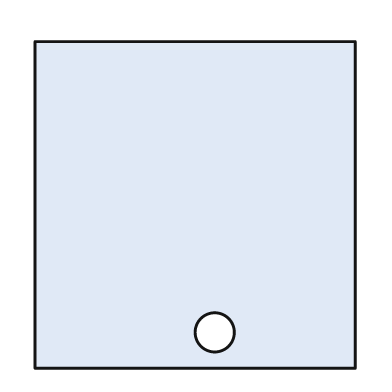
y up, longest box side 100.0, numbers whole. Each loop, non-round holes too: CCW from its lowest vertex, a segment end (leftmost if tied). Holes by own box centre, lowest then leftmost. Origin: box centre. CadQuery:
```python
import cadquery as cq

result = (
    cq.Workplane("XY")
    .moveTo(-49.0, -50.0)
    .lineTo(49.0, -50.0)
    .lineTo(49.0, 50.0)
    .lineTo(-49.0, 50.0)
    .close()
    .moveTo(6.0, -39.0)
    .circle(6.0)
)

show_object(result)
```